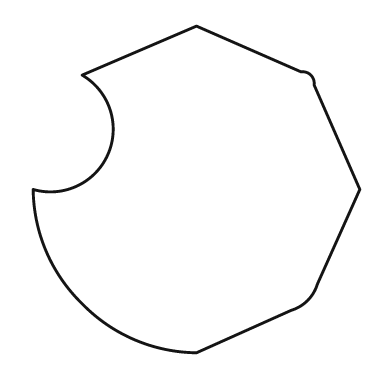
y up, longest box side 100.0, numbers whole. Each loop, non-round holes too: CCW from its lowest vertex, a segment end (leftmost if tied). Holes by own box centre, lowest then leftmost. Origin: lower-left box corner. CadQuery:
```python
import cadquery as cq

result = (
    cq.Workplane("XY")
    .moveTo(50.0, 0.0)
    .lineTo(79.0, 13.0)
    .threePointArc((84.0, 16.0), (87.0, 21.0))
    .lineTo(100.0, 50.0)
    .lineTo(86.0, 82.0)
    .threePointArc((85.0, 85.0), (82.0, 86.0))
    .lineTo(50.0, 100.0)
    .lineTo(15.0, 85.0)
    .threePointArc((23.0, 61.0), (0.0, 50.0))
    .threePointArc((4.0, 31.0), (15.0, 15.0))
    .threePointArc((31.0, 4.0), (50.0, 0.0))
    .close()
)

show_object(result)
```